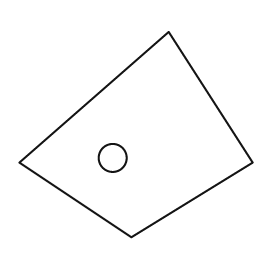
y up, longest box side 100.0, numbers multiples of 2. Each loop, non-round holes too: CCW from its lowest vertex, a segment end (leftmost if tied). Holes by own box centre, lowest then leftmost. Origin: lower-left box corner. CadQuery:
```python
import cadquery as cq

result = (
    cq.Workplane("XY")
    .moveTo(48.0, 0.0)
    .lineTo(100.0, 32.0)
    .lineTo(64.0, 88.0)
    .lineTo(0.0, 32.0)
    .close()
    .moveTo(40.0, 34.0)
    .circle(6.0)
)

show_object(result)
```